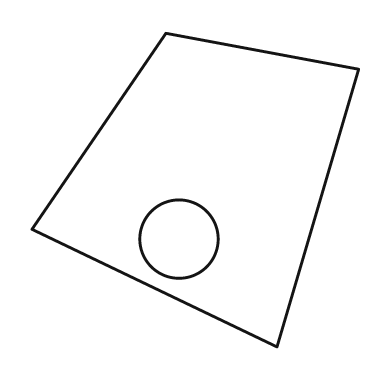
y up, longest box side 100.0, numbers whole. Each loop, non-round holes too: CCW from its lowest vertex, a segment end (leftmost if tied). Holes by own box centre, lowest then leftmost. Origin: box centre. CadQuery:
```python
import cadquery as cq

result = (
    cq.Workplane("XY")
    .moveTo(25.0, -48.0)
    .lineTo(50.0, 37.0)
    .lineTo(-9.0, 48.0)
    .lineTo(-50.0, -12.0)
    .close()
    .moveTo(-5.0, -15.0)
    .circle(12.0)
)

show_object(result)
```